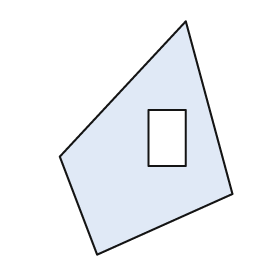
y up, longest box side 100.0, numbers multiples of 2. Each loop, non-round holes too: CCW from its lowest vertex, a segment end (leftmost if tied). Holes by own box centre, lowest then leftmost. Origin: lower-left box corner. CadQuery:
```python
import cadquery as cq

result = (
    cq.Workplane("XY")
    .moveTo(16.0, 0.0)
    .lineTo(74.0, 26.0)
    .lineTo(54.0, 100.0)
    .lineTo(0.0, 42.0)
    .close()
    .moveTo(38.0, 38.0)
    .lineTo(54.0, 38.0)
    .lineTo(54.0, 62.0)
    .lineTo(38.0, 62.0)
    .close()
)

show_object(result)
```